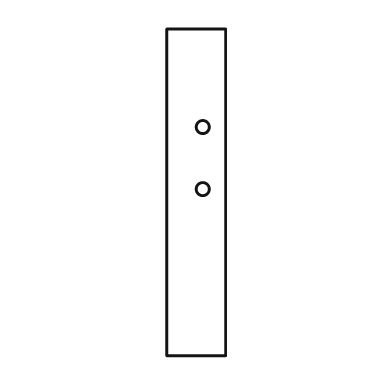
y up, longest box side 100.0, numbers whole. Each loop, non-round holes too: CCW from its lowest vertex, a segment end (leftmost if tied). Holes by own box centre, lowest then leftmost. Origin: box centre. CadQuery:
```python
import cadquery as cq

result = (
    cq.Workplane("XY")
    .moveTo(-9.0, -50.0)
    .lineTo(9.0, -50.0)
    .lineTo(9.0, 50.0)
    .lineTo(-9.0, 50.0)
    .close()
    .moveTo(2.0, 1.0)
    .circle(2.0)
    .moveTo(2.0, 20.0)
    .circle(2.0)
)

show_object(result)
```